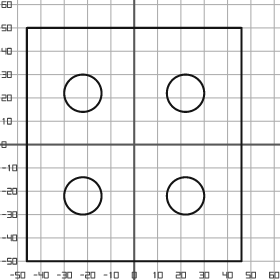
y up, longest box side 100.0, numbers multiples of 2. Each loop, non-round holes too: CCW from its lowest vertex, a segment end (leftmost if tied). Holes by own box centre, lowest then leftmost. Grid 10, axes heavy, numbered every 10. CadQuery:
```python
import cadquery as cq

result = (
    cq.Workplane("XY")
    .moveTo(-46.0, -50.0)
    .lineTo(46.0, -50.0)
    .lineTo(46.0, 50.0)
    .lineTo(-46.0, 50.0)
    .close()
    .moveTo(-22.0, -22.0)
    .circle(8.0)
    .moveTo(22.0, -22.0)
    .circle(8.0)
    .moveTo(-22.0, 22.0)
    .circle(8.0)
    .moveTo(22.0, 22.0)
    .circle(8.0)
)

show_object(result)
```